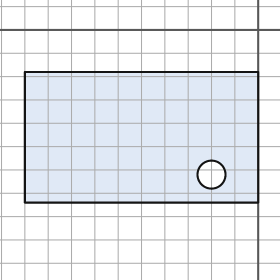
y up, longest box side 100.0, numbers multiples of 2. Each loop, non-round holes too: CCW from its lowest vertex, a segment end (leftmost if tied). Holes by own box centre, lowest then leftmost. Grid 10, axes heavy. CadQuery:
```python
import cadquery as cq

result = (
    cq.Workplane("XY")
    .moveTo(-100.0, -74.0)
    .lineTo(0.0, -74.0)
    .lineTo(0.0, -18.0)
    .lineTo(-100.0, -18.0)
    .close()
    .moveTo(-20.0, -62.0)
    .circle(6.0)
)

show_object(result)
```